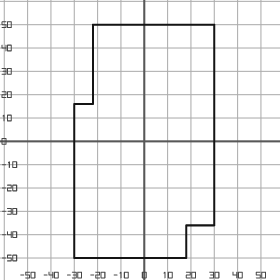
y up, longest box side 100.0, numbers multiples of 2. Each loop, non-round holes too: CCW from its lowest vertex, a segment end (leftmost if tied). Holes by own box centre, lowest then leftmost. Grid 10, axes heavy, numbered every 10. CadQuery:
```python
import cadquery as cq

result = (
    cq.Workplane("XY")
    .moveTo(-30.0, -50.0)
    .lineTo(18.0, -50.0)
    .lineTo(18.0, -36.0)
    .lineTo(30.0, -36.0)
    .lineTo(30.0, 50.0)
    .lineTo(-22.0, 50.0)
    .lineTo(-22.0, 16.0)
    .lineTo(-30.0, 16.0)
    .close()
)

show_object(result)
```